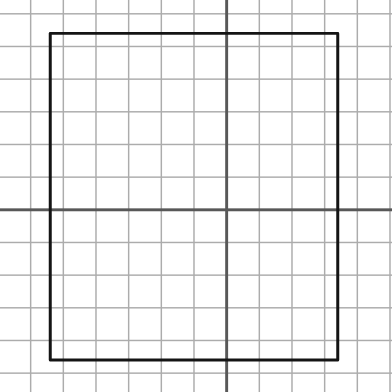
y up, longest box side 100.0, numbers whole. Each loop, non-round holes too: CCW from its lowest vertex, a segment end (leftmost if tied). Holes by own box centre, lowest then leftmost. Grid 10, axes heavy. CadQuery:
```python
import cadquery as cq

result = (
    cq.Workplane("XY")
    .moveTo(-54.0, -46.0)
    .lineTo(34.0, -46.0)
    .lineTo(34.0, 54.0)
    .lineTo(-54.0, 54.0)
    .close()
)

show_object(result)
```